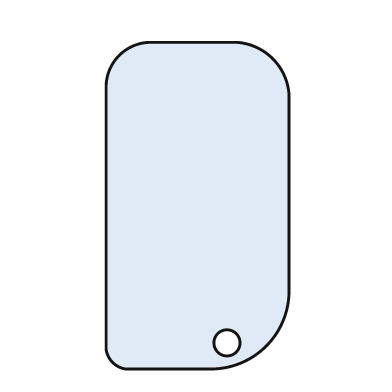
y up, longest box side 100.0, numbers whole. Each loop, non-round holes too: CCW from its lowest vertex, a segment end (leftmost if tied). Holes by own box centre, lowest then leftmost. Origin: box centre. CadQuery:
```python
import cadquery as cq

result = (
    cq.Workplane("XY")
    .moveTo(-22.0, -50.0)
    .lineTo(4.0, -50.0)
    .threePointArc((21.0, -43.0), (28.0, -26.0))
    .lineTo(28.0, 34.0)
    .threePointArc((23.0, 45.0), (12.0, 50.0))
    .lineTo(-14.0, 50.0)
    .threePointArc((-24.0, 46.0), (-28.0, 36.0))
    .lineTo(-28.0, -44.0)
    .threePointArc((-26.0, -48.0), (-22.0, -50.0))
    .close()
    .moveTo(9.0, -42.0)
    .circle(4.0)
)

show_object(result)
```